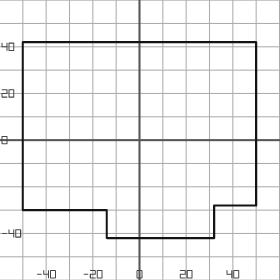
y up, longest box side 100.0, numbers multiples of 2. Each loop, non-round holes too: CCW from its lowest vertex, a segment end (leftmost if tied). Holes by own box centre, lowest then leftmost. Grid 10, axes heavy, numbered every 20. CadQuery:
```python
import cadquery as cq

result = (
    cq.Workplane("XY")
    .moveTo(-14.0, -42.0)
    .lineTo(32.0, -42.0)
    .lineTo(32.0, -28.0)
    .lineTo(50.0, -28.0)
    .lineTo(50.0, 42.0)
    .lineTo(-50.0, 42.0)
    .lineTo(-50.0, -30.0)
    .lineTo(-14.0, -30.0)
    .close()
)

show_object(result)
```